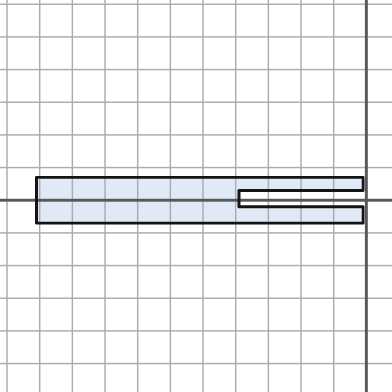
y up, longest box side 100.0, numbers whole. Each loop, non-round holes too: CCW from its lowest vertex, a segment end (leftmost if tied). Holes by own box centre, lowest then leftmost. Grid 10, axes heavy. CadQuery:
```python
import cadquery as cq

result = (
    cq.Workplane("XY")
    .moveTo(-101.0, -7.0)
    .lineTo(-1.0, -7.0)
    .lineTo(-1.0, -2.0)
    .lineTo(-39.0, -2.0)
    .lineTo(-39.0, 3.0)
    .lineTo(-1.0, 3.0)
    .lineTo(-1.0, 7.0)
    .lineTo(-101.0, 7.0)
    .close()
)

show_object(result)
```